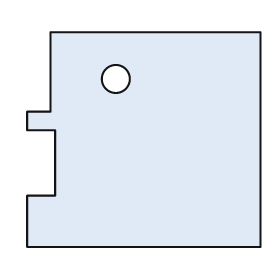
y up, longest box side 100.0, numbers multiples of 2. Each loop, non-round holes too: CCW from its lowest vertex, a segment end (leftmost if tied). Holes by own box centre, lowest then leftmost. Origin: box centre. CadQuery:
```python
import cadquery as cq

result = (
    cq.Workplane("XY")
    .moveTo(-50.0, -46.0)
    .lineTo(50.0, -46.0)
    .lineTo(50.0, 46.0)
    .lineTo(-40.0, 46.0)
    .lineTo(-40.0, 12.0)
    .lineTo(-50.0, 12.0)
    .lineTo(-50.0, 4.0)
    .lineTo(-38.0, 4.0)
    .lineTo(-38.0, -24.0)
    .lineTo(-50.0, -24.0)
    .close()
    .moveTo(-12.0, 26.0)
    .circle(6.0)
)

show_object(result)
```